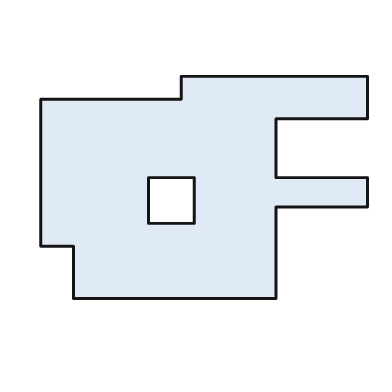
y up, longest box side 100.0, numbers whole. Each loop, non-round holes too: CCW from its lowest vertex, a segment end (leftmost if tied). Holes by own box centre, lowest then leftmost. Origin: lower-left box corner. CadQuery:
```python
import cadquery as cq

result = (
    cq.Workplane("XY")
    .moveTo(10.0, 0.0)
    .lineTo(72.0, 0.0)
    .lineTo(72.0, 28.0)
    .lineTo(100.0, 28.0)
    .lineTo(100.0, 37.0)
    .lineTo(72.0, 37.0)
    .lineTo(72.0, 55.0)
    .lineTo(100.0, 55.0)
    .lineTo(100.0, 68.0)
    .lineTo(43.0, 68.0)
    .lineTo(43.0, 61.0)
    .lineTo(0.0, 61.0)
    .lineTo(0.0, 16.0)
    .lineTo(10.0, 16.0)
    .close()
    .moveTo(33.0, 23.0)
    .lineTo(47.0, 23.0)
    .lineTo(47.0, 37.0)
    .lineTo(33.0, 37.0)
    .close()
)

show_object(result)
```